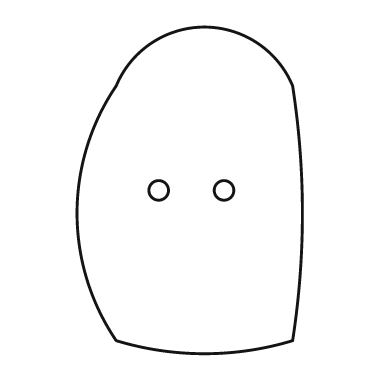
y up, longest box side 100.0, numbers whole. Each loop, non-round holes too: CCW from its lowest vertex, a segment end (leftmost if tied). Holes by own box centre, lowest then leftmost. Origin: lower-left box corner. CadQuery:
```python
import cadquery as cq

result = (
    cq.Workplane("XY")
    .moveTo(12.0, 4.0)
    .threePointArc((39.0, 0.0), (66.0, 4.0))
    .threePointArc((69.0, 43.0), (66.0, 82.0))
    .threePointArc((39.0, 100.0), (12.0, 82.0))
    .threePointArc((0.0, 43.0), (12.0, 4.0))
    .close()
    .moveTo(25.0, 50.0)
    .circle(3.0)
    .moveTo(45.0, 50.0)
    .circle(3.0)
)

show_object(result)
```